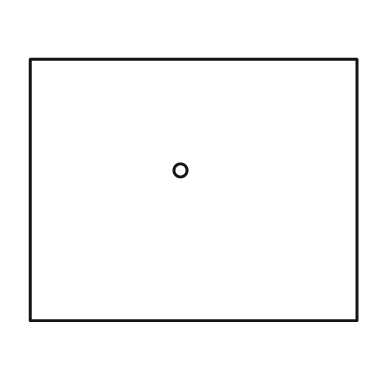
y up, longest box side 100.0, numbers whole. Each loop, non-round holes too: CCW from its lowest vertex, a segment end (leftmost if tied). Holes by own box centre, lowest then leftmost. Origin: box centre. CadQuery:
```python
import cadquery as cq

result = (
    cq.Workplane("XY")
    .moveTo(-50.0, -40.0)
    .lineTo(50.0, -40.0)
    .lineTo(50.0, 40.0)
    .lineTo(-50.0, 40.0)
    .close()
    .moveTo(-4.0, 6.0)
    .circle(2.0)
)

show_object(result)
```